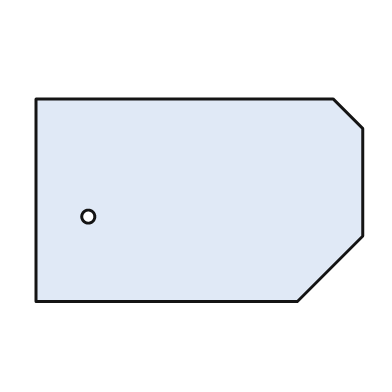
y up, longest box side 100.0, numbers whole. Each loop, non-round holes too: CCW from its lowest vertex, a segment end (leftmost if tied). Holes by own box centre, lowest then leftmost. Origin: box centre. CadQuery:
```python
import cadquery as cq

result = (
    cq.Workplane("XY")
    .moveTo(-50.0, -31.0)
    .lineTo(30.0, -31.0)
    .lineTo(50.0, -11.0)
    .lineTo(50.0, 22.0)
    .lineTo(41.0, 31.0)
    .lineTo(-50.0, 31.0)
    .close()
    .moveTo(-34.0, -5.0)
    .circle(2.0)
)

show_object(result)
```